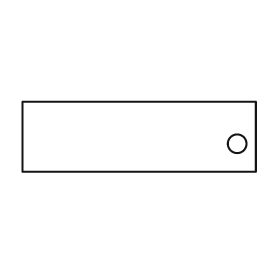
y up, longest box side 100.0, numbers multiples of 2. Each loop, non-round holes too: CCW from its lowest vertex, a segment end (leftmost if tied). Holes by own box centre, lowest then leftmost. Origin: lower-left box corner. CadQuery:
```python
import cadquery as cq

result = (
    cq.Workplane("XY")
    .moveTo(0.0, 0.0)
    .lineTo(100.0, 0.0)
    .lineTo(100.0, 30.0)
    .lineTo(0.0, 30.0)
    .close()
    .moveTo(92.0, 12.0)
    .circle(4.0)
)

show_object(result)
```